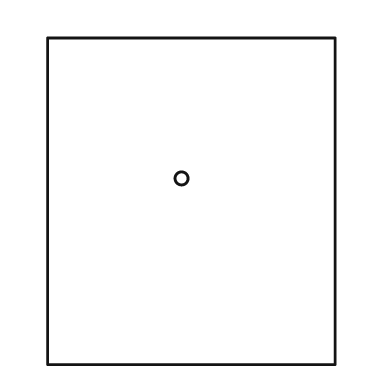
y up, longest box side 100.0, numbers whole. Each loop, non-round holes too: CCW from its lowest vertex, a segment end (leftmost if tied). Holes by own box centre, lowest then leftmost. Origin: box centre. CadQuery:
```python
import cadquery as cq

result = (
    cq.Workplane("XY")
    .moveTo(-44.0, -50.0)
    .lineTo(44.0, -50.0)
    .lineTo(44.0, 50.0)
    .lineTo(-44.0, 50.0)
    .close()
    .moveTo(-3.0, 7.0)
    .circle(2.0)
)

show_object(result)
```